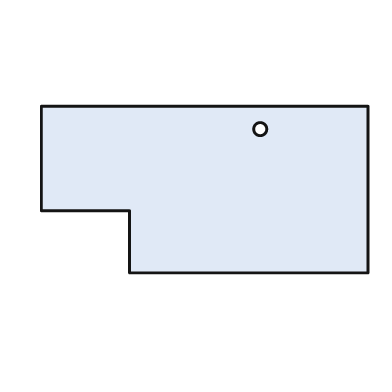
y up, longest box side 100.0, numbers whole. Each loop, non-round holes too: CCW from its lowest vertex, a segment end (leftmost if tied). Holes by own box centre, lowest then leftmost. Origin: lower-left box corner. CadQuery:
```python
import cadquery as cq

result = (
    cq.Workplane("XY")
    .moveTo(27.0, 0.0)
    .lineTo(100.0, 0.0)
    .lineTo(100.0, 51.0)
    .lineTo(0.0, 51.0)
    .lineTo(0.0, 19.0)
    .lineTo(27.0, 19.0)
    .close()
    .moveTo(67.0, 44.0)
    .circle(2.0)
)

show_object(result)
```